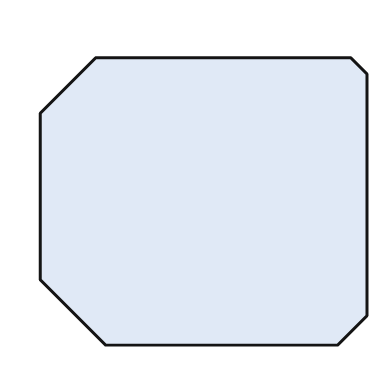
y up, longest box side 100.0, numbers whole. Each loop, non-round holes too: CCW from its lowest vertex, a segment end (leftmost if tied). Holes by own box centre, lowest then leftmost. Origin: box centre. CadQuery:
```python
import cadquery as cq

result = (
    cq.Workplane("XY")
    .moveTo(-30.0, -44.0)
    .lineTo(41.0, -44.0)
    .lineTo(50.0, -35.0)
    .lineTo(50.0, 39.0)
    .lineTo(45.0, 44.0)
    .lineTo(-33.0, 44.0)
    .lineTo(-50.0, 27.0)
    .lineTo(-50.0, -24.0)
    .close()
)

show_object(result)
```